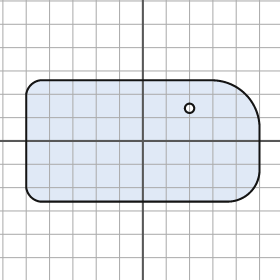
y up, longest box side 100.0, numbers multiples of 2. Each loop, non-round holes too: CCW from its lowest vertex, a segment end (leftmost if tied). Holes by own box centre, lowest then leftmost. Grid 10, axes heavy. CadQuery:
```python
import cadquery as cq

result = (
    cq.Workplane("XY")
    .moveTo(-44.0, -26.0)
    .lineTo(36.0, -26.0)
    .threePointArc((46.0, -22.0), (50.0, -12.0))
    .lineTo(50.0, 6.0)
    .threePointArc((44.0, 20.0), (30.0, 26.0))
    .lineTo(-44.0, 26.0)
    .threePointArc((-48.0, 24.0), (-50.0, 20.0))
    .lineTo(-50.0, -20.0)
    .threePointArc((-48.0, -24.0), (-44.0, -26.0))
    .close()
    .moveTo(20.0, 14.0)
    .circle(2.0)
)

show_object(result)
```